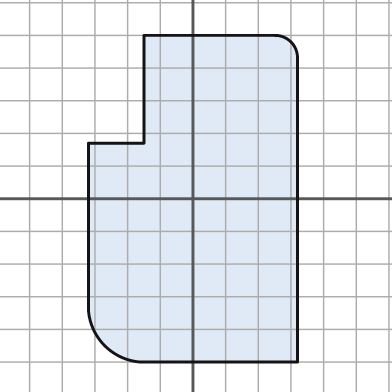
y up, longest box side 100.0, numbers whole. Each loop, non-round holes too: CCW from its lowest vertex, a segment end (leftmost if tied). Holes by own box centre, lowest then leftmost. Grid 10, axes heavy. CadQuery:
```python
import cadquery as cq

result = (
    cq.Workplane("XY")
    .moveTo(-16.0, -50.0)
    .lineTo(32.0, -50.0)
    .lineTo(32.0, 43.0)
    .threePointArc((30.0, 48.0), (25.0, 50.0))
    .lineTo(-15.0, 50.0)
    .lineTo(-15.0, 17.0)
    .lineTo(-32.0, 17.0)
    .lineTo(-32.0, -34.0)
    .threePointArc((-27.0, -45.0), (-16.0, -50.0))
    .close()
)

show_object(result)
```